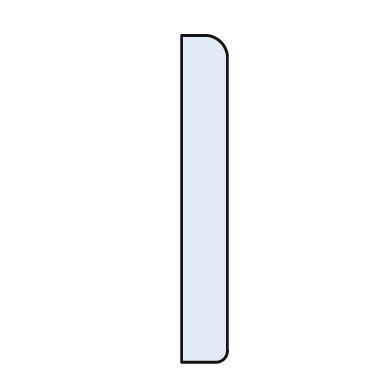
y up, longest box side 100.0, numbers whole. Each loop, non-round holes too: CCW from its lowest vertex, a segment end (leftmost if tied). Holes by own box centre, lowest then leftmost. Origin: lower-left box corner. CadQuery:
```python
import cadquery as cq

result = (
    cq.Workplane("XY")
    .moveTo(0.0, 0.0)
    .lineTo(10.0, 0.0)
    .threePointArc((13.0, 1.0), (14.0, 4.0))
    .lineTo(14.0, 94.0)
    .threePointArc((12.0, 98.0), (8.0, 100.0))
    .lineTo(0.0, 100.0)
    .close()
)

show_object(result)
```